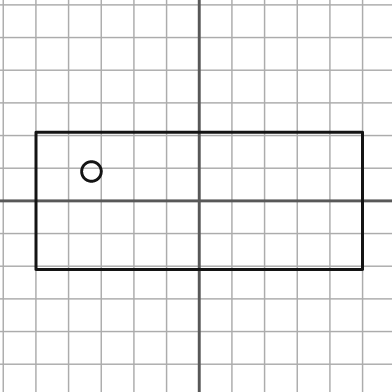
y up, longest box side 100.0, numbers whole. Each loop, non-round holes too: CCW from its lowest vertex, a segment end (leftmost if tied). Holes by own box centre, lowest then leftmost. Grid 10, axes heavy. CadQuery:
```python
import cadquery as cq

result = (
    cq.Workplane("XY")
    .moveTo(-50.0, -21.0)
    .lineTo(50.0, -21.0)
    .lineTo(50.0, 21.0)
    .lineTo(-50.0, 21.0)
    .close()
    .moveTo(-33.0, 9.0)
    .circle(3.0)
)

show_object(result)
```